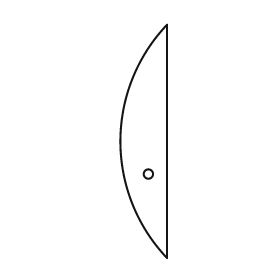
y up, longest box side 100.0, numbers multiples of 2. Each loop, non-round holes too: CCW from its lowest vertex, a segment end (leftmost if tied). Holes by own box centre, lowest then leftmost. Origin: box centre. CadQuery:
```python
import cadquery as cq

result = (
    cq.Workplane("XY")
    .moveTo(10.0, -50.0)
    .lineTo(10.0, 50.0)
    .threePointArc((-10.0, 0.0), (10.0, -50.0))
    .close()
    .moveTo(2.0, -14.0)
    .circle(2.0)
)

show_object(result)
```